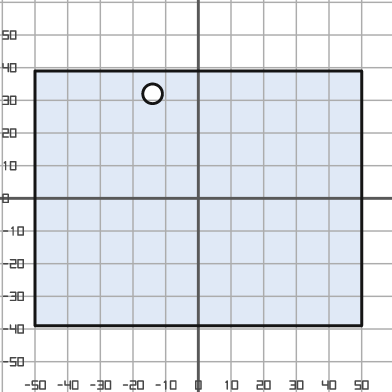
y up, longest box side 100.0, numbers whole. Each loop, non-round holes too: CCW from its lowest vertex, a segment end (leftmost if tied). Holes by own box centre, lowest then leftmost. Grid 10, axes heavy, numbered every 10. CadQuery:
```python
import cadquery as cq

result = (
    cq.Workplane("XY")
    .moveTo(-50.0, -39.0)
    .lineTo(50.0, -39.0)
    .lineTo(50.0, 39.0)
    .lineTo(-50.0, 39.0)
    .close()
    .moveTo(-14.0, 32.0)
    .circle(3.0)
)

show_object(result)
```